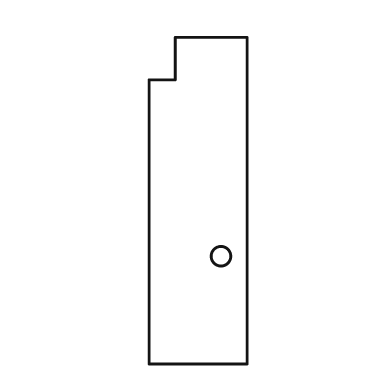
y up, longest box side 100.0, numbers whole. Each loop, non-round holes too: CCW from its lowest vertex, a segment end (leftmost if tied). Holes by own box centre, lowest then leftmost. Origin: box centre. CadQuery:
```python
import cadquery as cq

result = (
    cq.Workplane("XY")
    .moveTo(-15.0, -50.0)
    .lineTo(15.0, -50.0)
    .lineTo(15.0, 50.0)
    .lineTo(-7.0, 50.0)
    .lineTo(-7.0, 37.0)
    .lineTo(-15.0, 37.0)
    .close()
    .moveTo(7.0, -17.0)
    .circle(3.0)
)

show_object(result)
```